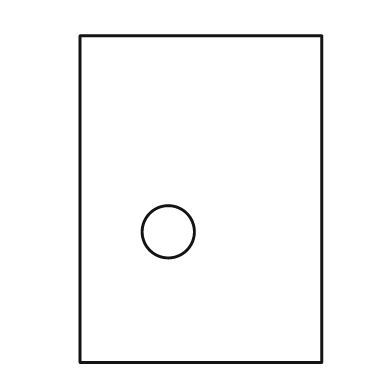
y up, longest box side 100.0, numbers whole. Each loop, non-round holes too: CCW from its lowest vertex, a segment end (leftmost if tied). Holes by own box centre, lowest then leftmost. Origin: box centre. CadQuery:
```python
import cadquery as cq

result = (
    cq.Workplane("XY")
    .moveTo(-37.0, -50.0)
    .lineTo(37.0, -50.0)
    .lineTo(37.0, 50.0)
    .lineTo(-37.0, 50.0)
    .close()
    .moveTo(-10.0, -10.0)
    .circle(8.0)
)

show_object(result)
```